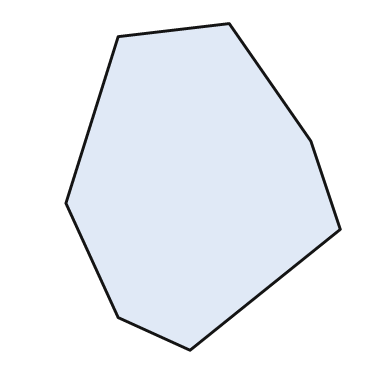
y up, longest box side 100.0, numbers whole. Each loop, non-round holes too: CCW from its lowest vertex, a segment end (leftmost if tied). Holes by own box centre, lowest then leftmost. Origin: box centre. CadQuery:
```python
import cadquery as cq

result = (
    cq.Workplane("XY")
    .moveTo(-4.0, -50.0)
    .lineTo(42.0, -13.0)
    .lineTo(33.0, 14.0)
    .lineTo(8.0, 50.0)
    .lineTo(-26.0, 46.0)
    .lineTo(-42.0, -5.0)
    .lineTo(-26.0, -40.0)
    .close()
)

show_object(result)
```